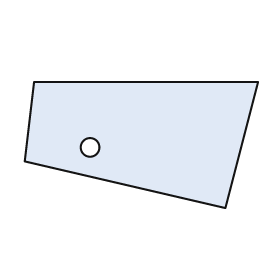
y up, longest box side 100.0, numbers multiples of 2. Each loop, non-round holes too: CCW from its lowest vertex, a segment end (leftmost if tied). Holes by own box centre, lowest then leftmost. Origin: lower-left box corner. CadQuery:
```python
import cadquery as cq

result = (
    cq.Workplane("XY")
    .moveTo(86.0, 0.0)
    .lineTo(100.0, 54.0)
    .lineTo(4.0, 54.0)
    .lineTo(0.0, 20.0)
    .close()
    .moveTo(28.0, 26.0)
    .circle(4.0)
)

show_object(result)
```